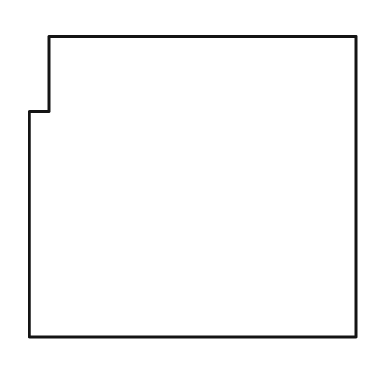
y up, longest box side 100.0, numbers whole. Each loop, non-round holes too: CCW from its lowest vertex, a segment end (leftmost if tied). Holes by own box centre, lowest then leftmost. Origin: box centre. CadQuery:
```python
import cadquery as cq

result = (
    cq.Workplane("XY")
    .moveTo(-50.0, -46.0)
    .lineTo(50.0, -46.0)
    .lineTo(50.0, 46.0)
    .lineTo(-44.0, 46.0)
    .lineTo(-44.0, 23.0)
    .lineTo(-50.0, 23.0)
    .close()
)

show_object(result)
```